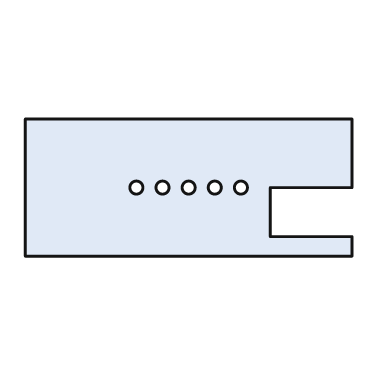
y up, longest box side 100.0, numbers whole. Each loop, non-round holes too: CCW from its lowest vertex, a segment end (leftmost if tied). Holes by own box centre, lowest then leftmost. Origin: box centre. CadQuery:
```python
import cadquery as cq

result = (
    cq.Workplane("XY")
    .moveTo(-50.0, -21.0)
    .lineTo(50.0, -21.0)
    .lineTo(50.0, -15.0)
    .lineTo(25.0, -15.0)
    .lineTo(25.0, 0.0)
    .lineTo(50.0, 0.0)
    .lineTo(50.0, 21.0)
    .lineTo(-50.0, 21.0)
    .close()
    .moveTo(-16.0, 0.0)
    .circle(2.0)
    .moveTo(-8.0, 0.0)
    .circle(2.0)
    .moveTo(0.0, 0.0)
    .circle(2.0)
    .moveTo(8.0, 0.0)
    .circle(2.0)
    .moveTo(16.0, 0.0)
    .circle(2.0)
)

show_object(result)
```